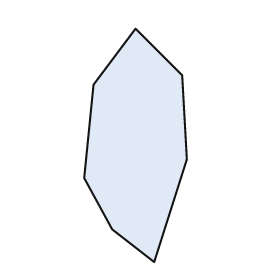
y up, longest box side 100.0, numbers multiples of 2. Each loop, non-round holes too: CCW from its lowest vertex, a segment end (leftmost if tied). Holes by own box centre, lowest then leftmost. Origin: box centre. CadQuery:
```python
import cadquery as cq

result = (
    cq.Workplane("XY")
    .moveTo(8.0, -50.0)
    .lineTo(22.0, -6.0)
    .lineTo(20.0, 30.0)
    .lineTo(0.0, 50.0)
    .lineTo(-18.0, 26.0)
    .lineTo(-22.0, -14.0)
    .lineTo(-10.0, -36.0)
    .close()
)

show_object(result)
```